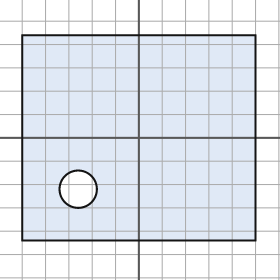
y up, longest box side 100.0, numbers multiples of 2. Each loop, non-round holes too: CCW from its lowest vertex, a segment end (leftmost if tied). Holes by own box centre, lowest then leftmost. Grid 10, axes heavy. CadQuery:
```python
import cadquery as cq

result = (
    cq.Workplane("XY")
    .moveTo(-50.0, -44.0)
    .lineTo(50.0, -44.0)
    .lineTo(50.0, 44.0)
    .lineTo(-50.0, 44.0)
    .close()
    .moveTo(-26.0, -22.0)
    .circle(8.0)
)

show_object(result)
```